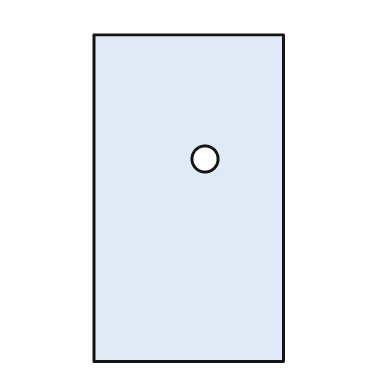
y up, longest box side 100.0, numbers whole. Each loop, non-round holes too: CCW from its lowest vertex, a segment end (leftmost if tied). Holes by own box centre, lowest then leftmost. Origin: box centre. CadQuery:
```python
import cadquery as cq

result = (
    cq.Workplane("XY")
    .moveTo(-29.0, -50.0)
    .lineTo(29.0, -50.0)
    .lineTo(29.0, 50.0)
    .lineTo(-29.0, 50.0)
    .close()
    .moveTo(5.0, 12.0)
    .circle(4.0)
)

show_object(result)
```